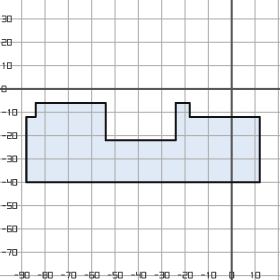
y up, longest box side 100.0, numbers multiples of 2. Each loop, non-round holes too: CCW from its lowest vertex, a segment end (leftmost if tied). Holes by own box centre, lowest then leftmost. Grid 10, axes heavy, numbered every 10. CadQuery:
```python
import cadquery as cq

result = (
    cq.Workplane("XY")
    .moveTo(-88.0, -40.0)
    .lineTo(12.0, -40.0)
    .lineTo(12.0, -12.0)
    .lineTo(-18.0, -12.0)
    .lineTo(-18.0, -6.0)
    .lineTo(-24.0, -6.0)
    .lineTo(-24.0, -22.0)
    .lineTo(-54.0, -22.0)
    .lineTo(-54.0, -6.0)
    .lineTo(-84.0, -6.0)
    .lineTo(-84.0, -12.0)
    .lineTo(-88.0, -12.0)
    .close()
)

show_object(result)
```